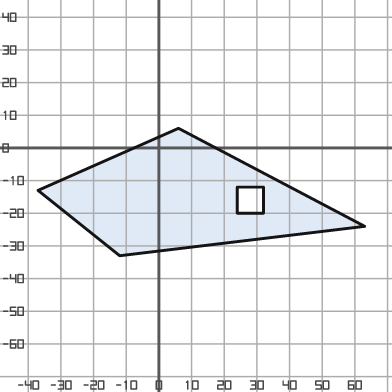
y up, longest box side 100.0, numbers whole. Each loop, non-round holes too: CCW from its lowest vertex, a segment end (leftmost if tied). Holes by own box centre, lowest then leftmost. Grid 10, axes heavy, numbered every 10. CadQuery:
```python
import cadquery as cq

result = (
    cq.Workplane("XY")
    .moveTo(-12.0, -33.0)
    .lineTo(63.0, -24.0)
    .lineTo(6.0, 6.0)
    .lineTo(-37.0, -13.0)
    .close()
    .moveTo(24.0, -20.0)
    .lineTo(32.0, -20.0)
    .lineTo(32.0, -12.0)
    .lineTo(24.0, -12.0)
    .close()
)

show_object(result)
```